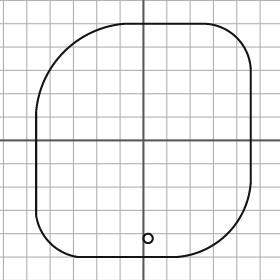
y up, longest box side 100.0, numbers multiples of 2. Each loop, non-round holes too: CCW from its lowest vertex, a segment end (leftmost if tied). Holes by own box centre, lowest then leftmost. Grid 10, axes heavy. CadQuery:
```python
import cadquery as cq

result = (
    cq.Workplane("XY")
    .moveTo(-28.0, -50.0)
    .lineTo(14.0, -50.0)
    .threePointArc((36.0, -40.0), (46.0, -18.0))
    .lineTo(46.0, 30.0)
    .threePointArc((40.0, 44.0), (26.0, 50.0))
    .lineTo(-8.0, 50.0)
    .threePointArc((-34.0, 38.0), (-46.0, 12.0))
    .lineTo(-46.0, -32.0)
    .threePointArc((-40.0, -44.0), (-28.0, -50.0))
    .close()
    .moveTo(2.0, -42.0)
    .circle(2.0)
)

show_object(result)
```